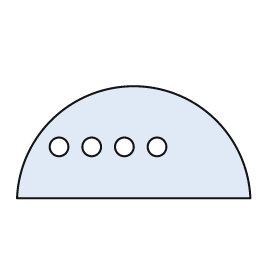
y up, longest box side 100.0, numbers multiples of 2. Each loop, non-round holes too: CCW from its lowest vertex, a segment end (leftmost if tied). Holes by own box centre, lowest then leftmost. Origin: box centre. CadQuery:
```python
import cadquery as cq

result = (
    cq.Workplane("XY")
    .moveTo(-50.0, -24.0)
    .lineTo(50.0, -24.0)
    .threePointArc((0.0, 24.0), (-50.0, -24.0))
    .close()
    .moveTo(-32.0, -2.0)
    .circle(4.0)
    .moveTo(-18.0, -2.0)
    .circle(4.0)
    .moveTo(-4.0, -2.0)
    .circle(4.0)
    .moveTo(10.0, -2.0)
    .circle(4.0)
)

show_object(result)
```